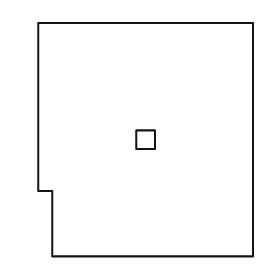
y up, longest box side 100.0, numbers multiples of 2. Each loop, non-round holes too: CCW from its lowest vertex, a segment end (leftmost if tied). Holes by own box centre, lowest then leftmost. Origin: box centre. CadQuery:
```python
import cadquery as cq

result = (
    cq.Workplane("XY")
    .moveTo(-40.0, -50.0)
    .lineTo(46.0, -50.0)
    .lineTo(46.0, 50.0)
    .lineTo(-46.0, 50.0)
    .lineTo(-46.0, -22.0)
    .lineTo(-40.0, -22.0)
    .close()
    .moveTo(-4.0, -4.0)
    .lineTo(4.0, -4.0)
    .lineTo(4.0, 4.0)
    .lineTo(-4.0, 4.0)
    .close()
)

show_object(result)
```